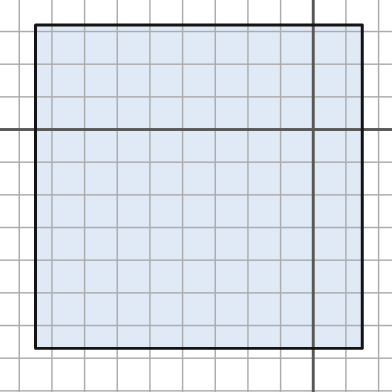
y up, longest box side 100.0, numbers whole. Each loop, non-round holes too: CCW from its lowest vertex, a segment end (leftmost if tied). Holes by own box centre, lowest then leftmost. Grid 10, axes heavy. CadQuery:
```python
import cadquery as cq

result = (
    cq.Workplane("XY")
    .moveTo(-85.0, -67.0)
    .lineTo(15.0, -67.0)
    .lineTo(15.0, 32.0)
    .lineTo(-85.0, 32.0)
    .close()
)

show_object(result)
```